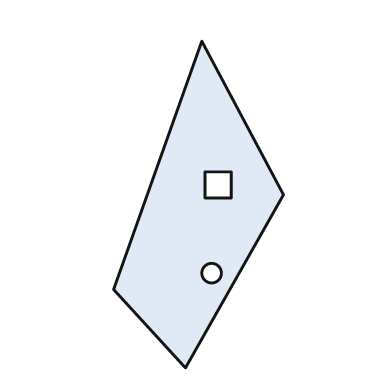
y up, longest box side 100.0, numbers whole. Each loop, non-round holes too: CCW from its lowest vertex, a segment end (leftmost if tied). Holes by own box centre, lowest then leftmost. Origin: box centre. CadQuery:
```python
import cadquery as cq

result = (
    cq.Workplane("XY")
    .moveTo(-4.0, -50.0)
    .lineTo(26.0, 3.0)
    .lineTo(1.0, 50.0)
    .lineTo(-26.0, -26.0)
    .close()
    .moveTo(4.0, -21.0)
    .circle(3.0)
    .moveTo(2.0, 2.0)
    .lineTo(10.0, 2.0)
    .lineTo(10.0, 10.0)
    .lineTo(2.0, 10.0)
    .close()
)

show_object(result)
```